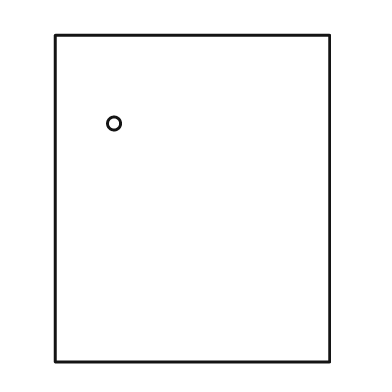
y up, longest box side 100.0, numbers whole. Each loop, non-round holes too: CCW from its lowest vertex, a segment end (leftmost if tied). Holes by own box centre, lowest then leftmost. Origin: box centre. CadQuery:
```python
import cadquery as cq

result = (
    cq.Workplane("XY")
    .moveTo(-42.0, -50.0)
    .lineTo(42.0, -50.0)
    .lineTo(42.0, 50.0)
    .lineTo(-42.0, 50.0)
    .close()
    .moveTo(-24.0, 23.0)
    .circle(2.0)
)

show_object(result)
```